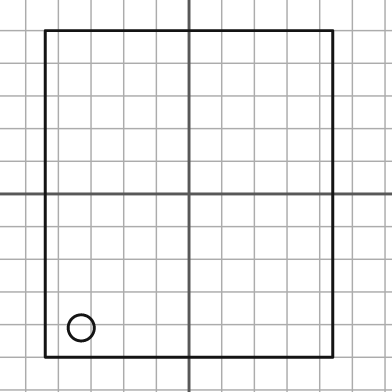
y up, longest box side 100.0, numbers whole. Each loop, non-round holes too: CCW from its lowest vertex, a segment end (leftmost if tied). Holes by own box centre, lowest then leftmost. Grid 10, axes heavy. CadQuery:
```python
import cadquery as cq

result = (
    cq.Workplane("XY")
    .moveTo(-44.0, -50.0)
    .lineTo(44.0, -50.0)
    .lineTo(44.0, 50.0)
    .lineTo(-44.0, 50.0)
    .close()
    .moveTo(-33.0, -41.0)
    .circle(4.0)
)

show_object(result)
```